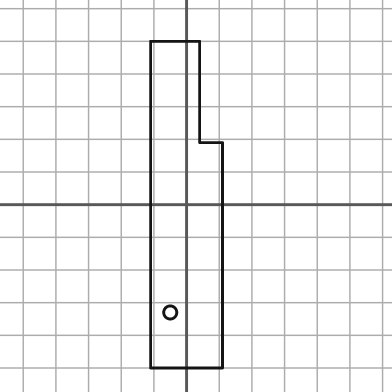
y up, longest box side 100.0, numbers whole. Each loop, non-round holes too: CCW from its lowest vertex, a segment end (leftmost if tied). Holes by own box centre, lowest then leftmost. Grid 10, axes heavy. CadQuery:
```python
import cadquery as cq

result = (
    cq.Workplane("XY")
    .moveTo(-11.0, -50.0)
    .lineTo(11.0, -50.0)
    .lineTo(11.0, 19.0)
    .lineTo(4.0, 19.0)
    .lineTo(4.0, 50.0)
    .lineTo(-11.0, 50.0)
    .close()
    .moveTo(-5.0, -33.0)
    .circle(2.0)
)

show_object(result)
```